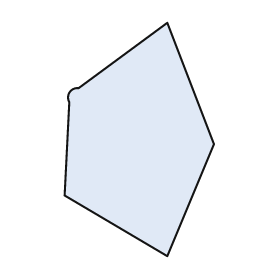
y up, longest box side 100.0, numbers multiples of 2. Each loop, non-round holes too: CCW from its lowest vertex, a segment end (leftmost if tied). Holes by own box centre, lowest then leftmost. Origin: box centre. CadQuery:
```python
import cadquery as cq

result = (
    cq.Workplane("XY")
    .moveTo(12.0, -50.0)
    .lineTo(32.0, -2.0)
    .lineTo(12.0, 50.0)
    .lineTo(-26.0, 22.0)
    .threePointArc((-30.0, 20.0), (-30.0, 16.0))
    .lineTo(-32.0, -24.0)
    .close()
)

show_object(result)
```